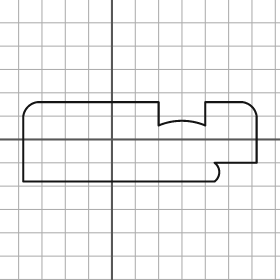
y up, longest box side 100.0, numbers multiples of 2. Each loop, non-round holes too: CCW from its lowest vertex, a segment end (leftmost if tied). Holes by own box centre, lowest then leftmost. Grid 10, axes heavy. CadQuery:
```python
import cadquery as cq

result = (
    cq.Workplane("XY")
    .moveTo(-38.0, -18.0)
    .lineTo(44.0, -18.0)
    .threePointArc((46.0, -14.0), (44.0, -10.0))
    .lineTo(62.0, -10.0)
    .lineTo(62.0, 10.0)
    .threePointArc((60.0, 14.0), (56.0, 16.0))
    .lineTo(40.0, 16.0)
    .lineTo(40.0, 6.0)
    .threePointArc((30.0, 8.0), (20.0, 6.0))
    .lineTo(20.0, 16.0)
    .lineTo(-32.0, 16.0)
    .threePointArc((-36.0, 14.0), (-38.0, 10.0))
    .close()
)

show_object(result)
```